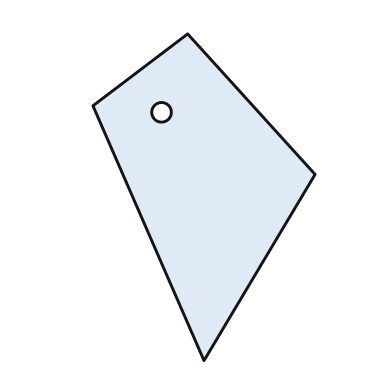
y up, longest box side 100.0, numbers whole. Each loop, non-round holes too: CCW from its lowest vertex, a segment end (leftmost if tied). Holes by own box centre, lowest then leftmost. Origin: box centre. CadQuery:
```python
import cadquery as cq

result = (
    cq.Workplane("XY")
    .moveTo(0.0, -50.0)
    .lineTo(34.0, 7.0)
    .lineTo(-5.0, 50.0)
    .lineTo(-34.0, 28.0)
    .close()
    .moveTo(-13.0, 26.0)
    .circle(3.0)
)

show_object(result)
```